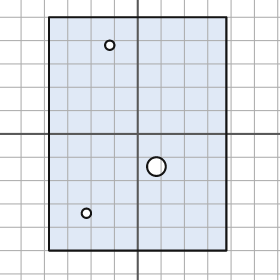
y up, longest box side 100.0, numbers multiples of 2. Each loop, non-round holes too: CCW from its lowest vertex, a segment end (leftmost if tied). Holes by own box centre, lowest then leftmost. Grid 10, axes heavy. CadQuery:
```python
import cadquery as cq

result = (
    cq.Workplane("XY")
    .moveTo(-38.0, -50.0)
    .lineTo(38.0, -50.0)
    .lineTo(38.0, 50.0)
    .lineTo(-38.0, 50.0)
    .close()
    .moveTo(-22.0, -34.0)
    .circle(2.0)
    .moveTo(8.0, -14.0)
    .circle(4.0)
    .moveTo(-12.0, 38.0)
    .circle(2.0)
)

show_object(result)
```